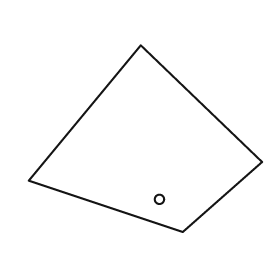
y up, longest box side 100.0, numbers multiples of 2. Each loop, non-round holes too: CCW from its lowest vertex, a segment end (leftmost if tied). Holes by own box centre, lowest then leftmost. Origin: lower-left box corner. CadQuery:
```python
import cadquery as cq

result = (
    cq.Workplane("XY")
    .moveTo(66.0, 0.0)
    .lineTo(100.0, 30.0)
    .lineTo(48.0, 80.0)
    .lineTo(0.0, 22.0)
    .close()
    .moveTo(56.0, 14.0)
    .circle(2.0)
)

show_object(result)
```